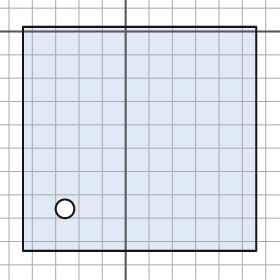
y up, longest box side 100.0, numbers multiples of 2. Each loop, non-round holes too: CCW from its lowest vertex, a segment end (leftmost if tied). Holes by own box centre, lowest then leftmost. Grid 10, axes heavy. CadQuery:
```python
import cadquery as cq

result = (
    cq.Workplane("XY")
    .moveTo(-44.0, -94.0)
    .lineTo(56.0, -94.0)
    .lineTo(56.0, 2.0)
    .lineTo(-44.0, 2.0)
    .close()
    .moveTo(-26.0, -76.0)
    .circle(4.0)
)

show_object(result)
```